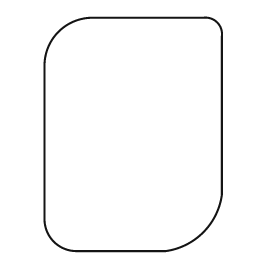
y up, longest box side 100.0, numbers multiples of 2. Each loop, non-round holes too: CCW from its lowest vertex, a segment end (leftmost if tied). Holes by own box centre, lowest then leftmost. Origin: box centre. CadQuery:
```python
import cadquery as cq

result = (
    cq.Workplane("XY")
    .moveTo(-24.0, -50.0)
    .lineTo(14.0, -50.0)
    .threePointArc((30.0, -42.0), (38.0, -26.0))
    .lineTo(38.0, 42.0)
    .threePointArc((36.0, 48.0), (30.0, 50.0))
    .lineTo(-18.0, 50.0)
    .threePointArc((-32.0, 44.0), (-38.0, 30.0))
    .lineTo(-38.0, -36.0)
    .threePointArc((-34.0, -46.0), (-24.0, -50.0))
    .close()
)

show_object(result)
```